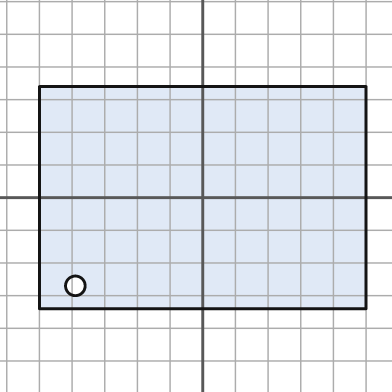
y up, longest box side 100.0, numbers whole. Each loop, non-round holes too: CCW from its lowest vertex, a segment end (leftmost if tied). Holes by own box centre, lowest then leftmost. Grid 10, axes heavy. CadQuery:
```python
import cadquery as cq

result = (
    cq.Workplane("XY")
    .moveTo(-50.0, -34.0)
    .lineTo(50.0, -34.0)
    .lineTo(50.0, 34.0)
    .lineTo(-50.0, 34.0)
    .close()
    .moveTo(-39.0, -27.0)
    .circle(3.0)
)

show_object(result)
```